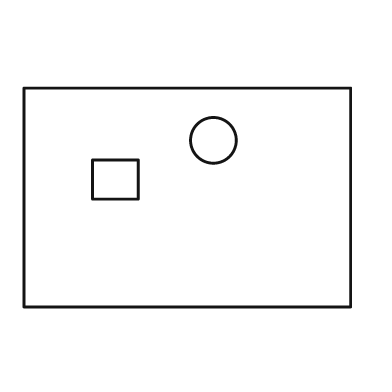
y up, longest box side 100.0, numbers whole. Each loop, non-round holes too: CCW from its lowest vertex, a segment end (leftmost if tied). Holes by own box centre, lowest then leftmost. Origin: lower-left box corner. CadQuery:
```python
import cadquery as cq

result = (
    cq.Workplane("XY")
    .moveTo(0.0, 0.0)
    .lineTo(100.0, 0.0)
    .lineTo(100.0, 67.0)
    .lineTo(0.0, 67.0)
    .close()
    .moveTo(21.0, 33.0)
    .lineTo(35.0, 33.0)
    .lineTo(35.0, 45.0)
    .lineTo(21.0, 45.0)
    .close()
    .moveTo(58.0, 51.0)
    .circle(7.0)
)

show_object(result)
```